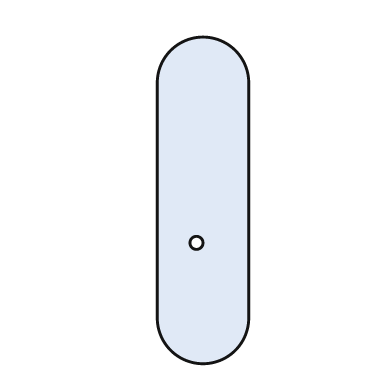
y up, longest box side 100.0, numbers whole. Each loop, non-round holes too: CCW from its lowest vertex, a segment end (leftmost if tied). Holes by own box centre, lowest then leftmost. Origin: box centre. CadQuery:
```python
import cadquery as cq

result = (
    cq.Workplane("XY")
    .moveTo(-14.0, -36.0)
    .threePointArc((0.0, -50.0), (14.0, -36.0))
    .lineTo(14.0, 36.0)
    .threePointArc((0.0, 50.0), (-14.0, 36.0))
    .close()
    .moveTo(-2.0, -13.0)
    .circle(2.0)
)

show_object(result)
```